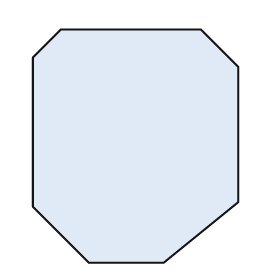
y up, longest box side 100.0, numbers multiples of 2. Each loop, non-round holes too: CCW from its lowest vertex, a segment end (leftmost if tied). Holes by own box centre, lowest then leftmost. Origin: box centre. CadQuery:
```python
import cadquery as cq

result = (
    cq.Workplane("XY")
    .moveTo(-20.0, -50.0)
    .lineTo(12.0, -50.0)
    .lineTo(44.0, -24.0)
    .lineTo(44.0, 34.0)
    .lineTo(28.0, 50.0)
    .lineTo(-32.0, 50.0)
    .lineTo(-44.0, 38.0)
    .lineTo(-44.0, -26.0)
    .close()
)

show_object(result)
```